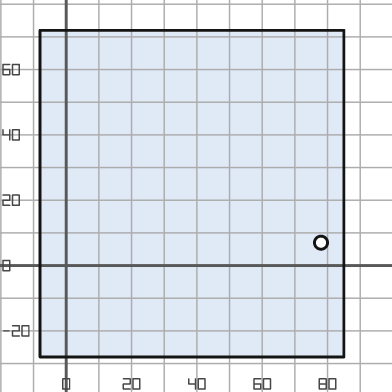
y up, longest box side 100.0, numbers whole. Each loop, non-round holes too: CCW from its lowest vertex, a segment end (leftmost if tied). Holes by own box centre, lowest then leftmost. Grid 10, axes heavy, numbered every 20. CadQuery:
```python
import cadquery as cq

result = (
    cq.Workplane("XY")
    .moveTo(-8.0, -28.0)
    .lineTo(85.0, -28.0)
    .lineTo(85.0, 72.0)
    .lineTo(-8.0, 72.0)
    .close()
    .moveTo(78.0, 7.0)
    .circle(2.0)
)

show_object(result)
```